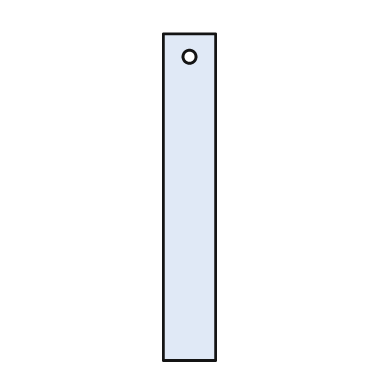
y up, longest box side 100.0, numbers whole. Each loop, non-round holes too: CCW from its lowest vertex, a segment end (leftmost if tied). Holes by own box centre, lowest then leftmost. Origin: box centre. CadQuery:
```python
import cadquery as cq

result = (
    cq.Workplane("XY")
    .moveTo(-8.0, -50.0)
    .lineTo(8.0, -50.0)
    .lineTo(8.0, 50.0)
    .lineTo(-8.0, 50.0)
    .close()
    .moveTo(0.0, 43.0)
    .circle(2.0)
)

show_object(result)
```